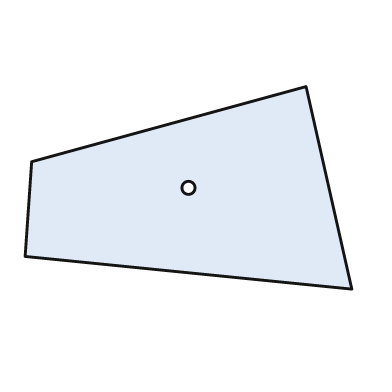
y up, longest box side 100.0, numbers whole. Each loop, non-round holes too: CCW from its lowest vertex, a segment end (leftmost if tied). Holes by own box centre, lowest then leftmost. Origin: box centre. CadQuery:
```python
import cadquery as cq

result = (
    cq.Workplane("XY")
    .moveTo(50.0, -31.0)
    .lineTo(36.0, 31.0)
    .lineTo(-48.0, 8.0)
    .lineTo(-50.0, -21.0)
    .close()
    .moveTo(0.0, 0.0)
    .circle(2.0)
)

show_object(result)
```